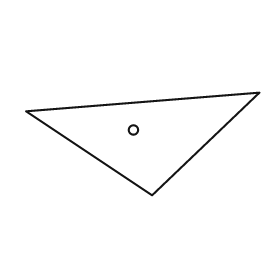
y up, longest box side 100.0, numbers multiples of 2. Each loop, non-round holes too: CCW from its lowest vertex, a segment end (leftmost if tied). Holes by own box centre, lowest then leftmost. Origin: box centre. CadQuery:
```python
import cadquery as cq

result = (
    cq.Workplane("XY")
    .moveTo(4.0, -22.0)
    .lineTo(50.0, 22.0)
    .lineTo(-50.0, 14.0)
    .close()
    .moveTo(-4.0, 6.0)
    .circle(2.0)
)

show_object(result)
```